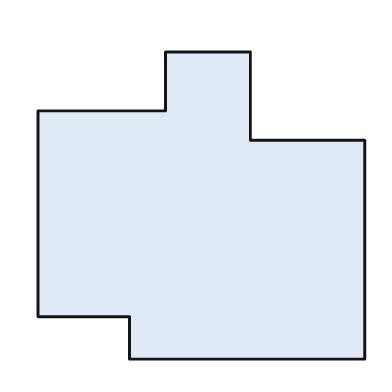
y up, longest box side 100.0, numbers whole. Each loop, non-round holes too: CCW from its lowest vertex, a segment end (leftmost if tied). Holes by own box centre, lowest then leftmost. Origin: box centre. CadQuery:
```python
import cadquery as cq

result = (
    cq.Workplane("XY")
    .moveTo(-22.0, -47.0)
    .lineTo(50.0, -47.0)
    .lineTo(50.0, 20.0)
    .lineTo(15.0, 20.0)
    .lineTo(15.0, 47.0)
    .lineTo(-11.0, 47.0)
    .lineTo(-11.0, 29.0)
    .lineTo(-50.0, 29.0)
    .lineTo(-50.0, -34.0)
    .lineTo(-22.0, -34.0)
    .close()
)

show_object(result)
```